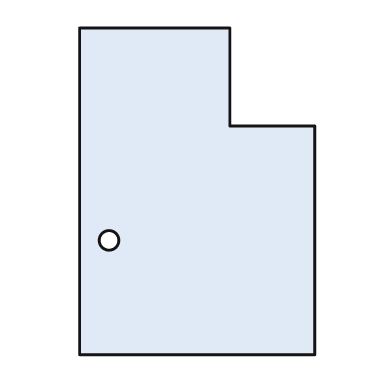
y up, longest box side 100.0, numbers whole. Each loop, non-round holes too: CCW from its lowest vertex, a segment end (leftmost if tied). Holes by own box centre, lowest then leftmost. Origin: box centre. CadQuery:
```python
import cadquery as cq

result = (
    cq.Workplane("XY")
    .moveTo(-36.0, -50.0)
    .lineTo(36.0, -50.0)
    .lineTo(36.0, 20.0)
    .lineTo(10.0, 20.0)
    .lineTo(10.0, 50.0)
    .lineTo(-36.0, 50.0)
    .close()
    .moveTo(-27.0, -15.0)
    .circle(3.0)
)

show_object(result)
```